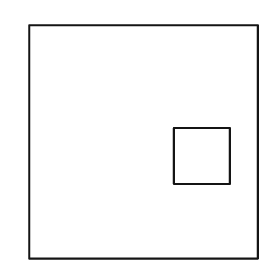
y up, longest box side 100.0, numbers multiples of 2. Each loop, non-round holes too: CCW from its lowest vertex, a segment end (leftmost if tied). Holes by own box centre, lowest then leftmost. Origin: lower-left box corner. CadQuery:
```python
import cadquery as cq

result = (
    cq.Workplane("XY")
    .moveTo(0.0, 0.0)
    .lineTo(98.0, 0.0)
    .lineTo(98.0, 100.0)
    .lineTo(0.0, 100.0)
    .close()
    .moveTo(62.0, 32.0)
    .lineTo(86.0, 32.0)
    .lineTo(86.0, 56.0)
    .lineTo(62.0, 56.0)
    .close()
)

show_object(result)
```